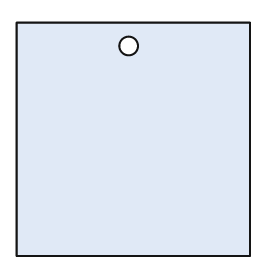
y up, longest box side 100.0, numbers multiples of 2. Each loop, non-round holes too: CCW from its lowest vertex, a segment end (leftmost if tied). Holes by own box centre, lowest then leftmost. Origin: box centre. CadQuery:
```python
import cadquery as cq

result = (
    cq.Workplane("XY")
    .moveTo(-50.0, -50.0)
    .lineTo(50.0, -50.0)
    .lineTo(50.0, 50.0)
    .lineTo(-50.0, 50.0)
    .close()
    .moveTo(-2.0, 40.0)
    .circle(4.0)
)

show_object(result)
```